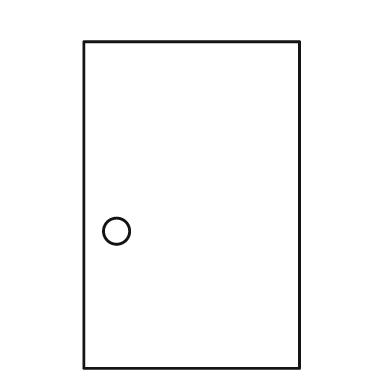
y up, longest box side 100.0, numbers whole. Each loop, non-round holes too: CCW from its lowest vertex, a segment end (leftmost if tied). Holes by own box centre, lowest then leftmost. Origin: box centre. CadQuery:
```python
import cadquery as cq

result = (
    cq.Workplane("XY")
    .moveTo(-33.0, -50.0)
    .lineTo(33.0, -50.0)
    .lineTo(33.0, 50.0)
    .lineTo(-33.0, 50.0)
    .close()
    .moveTo(-23.0, -8.0)
    .circle(4.0)
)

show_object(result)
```